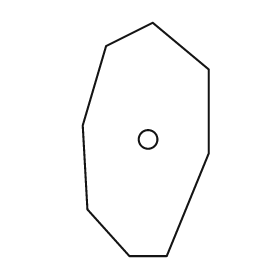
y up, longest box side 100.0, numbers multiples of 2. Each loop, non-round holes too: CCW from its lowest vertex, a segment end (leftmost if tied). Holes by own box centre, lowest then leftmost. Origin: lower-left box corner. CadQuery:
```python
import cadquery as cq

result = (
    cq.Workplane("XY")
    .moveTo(20.0, 0.0)
    .lineTo(36.0, 0.0)
    .lineTo(54.0, 44.0)
    .lineTo(54.0, 80.0)
    .lineTo(30.0, 100.0)
    .lineTo(10.0, 90.0)
    .lineTo(0.0, 56.0)
    .lineTo(2.0, 20.0)
    .close()
    .moveTo(28.0, 50.0)
    .circle(4.0)
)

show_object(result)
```